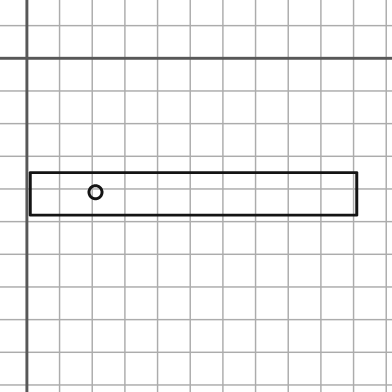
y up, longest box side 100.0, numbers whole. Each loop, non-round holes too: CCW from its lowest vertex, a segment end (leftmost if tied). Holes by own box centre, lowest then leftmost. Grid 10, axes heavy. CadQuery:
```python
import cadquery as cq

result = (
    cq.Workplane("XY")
    .moveTo(1.0, -48.0)
    .lineTo(101.0, -48.0)
    .lineTo(101.0, -35.0)
    .lineTo(1.0, -35.0)
    .close()
    .moveTo(21.0, -41.0)
    .circle(2.0)
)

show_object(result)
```